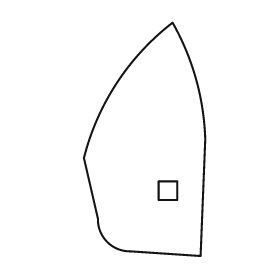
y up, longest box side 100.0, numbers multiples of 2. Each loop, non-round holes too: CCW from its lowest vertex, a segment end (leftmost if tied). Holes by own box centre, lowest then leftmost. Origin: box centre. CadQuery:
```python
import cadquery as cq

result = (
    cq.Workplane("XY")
    .moveTo(24.0, -50.0)
    .lineTo(26.0, 0.0)
    .threePointArc((22.0, 26.0), (12.0, 50.0))
    .threePointArc((-12.0, 24.0), (-26.0, -8.0))
    .lineTo(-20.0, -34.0)
    .threePointArc((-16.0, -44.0), (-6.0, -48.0))
    .close()
    .moveTo(6.0, -26.0)
    .lineTo(14.0, -26.0)
    .lineTo(14.0, -18.0)
    .lineTo(6.0, -18.0)
    .close()
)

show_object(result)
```